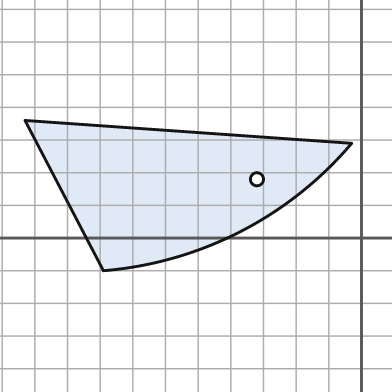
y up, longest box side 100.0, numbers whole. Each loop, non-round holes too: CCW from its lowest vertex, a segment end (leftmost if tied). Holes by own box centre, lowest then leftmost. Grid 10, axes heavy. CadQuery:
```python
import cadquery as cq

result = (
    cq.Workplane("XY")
    .moveTo(-79.0, -10.0)
    .threePointArc((-37.0, 2.0), (-3.0, 29.0))
    .lineTo(-103.0, 36.0)
    .close()
    .moveTo(-32.0, 18.0)
    .circle(2.0)
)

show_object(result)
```